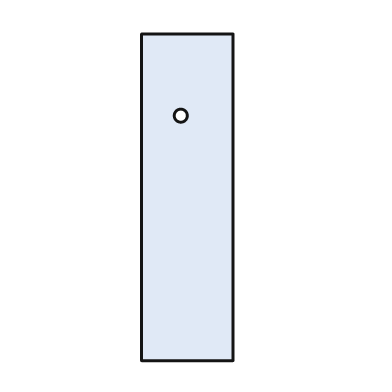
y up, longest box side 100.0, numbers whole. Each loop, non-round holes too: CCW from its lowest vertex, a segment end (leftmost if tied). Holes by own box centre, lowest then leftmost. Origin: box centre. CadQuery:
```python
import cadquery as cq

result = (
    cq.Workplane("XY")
    .moveTo(-14.0, -50.0)
    .lineTo(14.0, -50.0)
    .lineTo(14.0, 50.0)
    .lineTo(-14.0, 50.0)
    .close()
    .moveTo(-2.0, 25.0)
    .circle(2.0)
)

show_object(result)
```